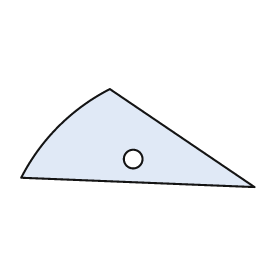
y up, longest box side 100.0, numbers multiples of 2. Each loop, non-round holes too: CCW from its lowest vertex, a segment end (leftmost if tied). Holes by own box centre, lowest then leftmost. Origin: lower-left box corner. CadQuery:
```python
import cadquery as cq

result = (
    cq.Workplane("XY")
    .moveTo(100.0, 0.0)
    .lineTo(38.0, 42.0)
    .threePointArc((16.0, 26.0), (0.0, 4.0))
    .close()
    .moveTo(48.0, 12.0)
    .circle(4.0)
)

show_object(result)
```